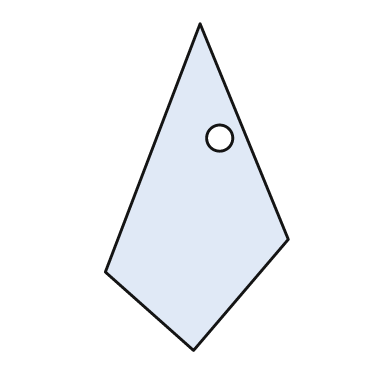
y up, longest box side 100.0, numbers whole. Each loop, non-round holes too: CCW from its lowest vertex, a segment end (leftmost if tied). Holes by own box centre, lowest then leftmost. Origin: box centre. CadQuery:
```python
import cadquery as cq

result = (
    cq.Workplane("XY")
    .moveTo(-1.0, -50.0)
    .lineTo(28.0, -16.0)
    .lineTo(1.0, 50.0)
    .lineTo(-28.0, -26.0)
    .close()
    .moveTo(7.0, 15.0)
    .circle(4.0)
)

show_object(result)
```